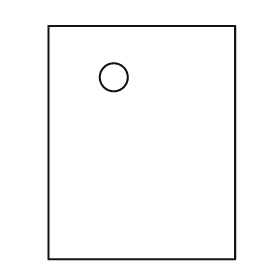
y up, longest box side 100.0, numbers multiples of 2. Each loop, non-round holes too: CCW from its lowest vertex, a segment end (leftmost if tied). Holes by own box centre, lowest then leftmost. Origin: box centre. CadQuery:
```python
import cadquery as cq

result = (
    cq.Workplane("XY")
    .moveTo(-40.0, -50.0)
    .lineTo(40.0, -50.0)
    .lineTo(40.0, 50.0)
    .lineTo(-40.0, 50.0)
    .close()
    .moveTo(-12.0, 28.0)
    .circle(6.0)
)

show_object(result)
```